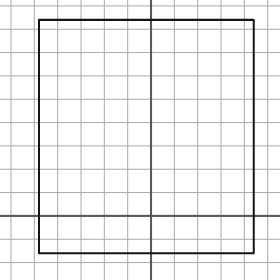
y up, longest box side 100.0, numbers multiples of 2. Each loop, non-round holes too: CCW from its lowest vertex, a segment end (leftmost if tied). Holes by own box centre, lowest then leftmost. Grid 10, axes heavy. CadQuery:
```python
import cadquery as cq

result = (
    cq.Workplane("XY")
    .moveTo(-48.0, -16.0)
    .lineTo(44.0, -16.0)
    .lineTo(44.0, 84.0)
    .lineTo(-48.0, 84.0)
    .close()
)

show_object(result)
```